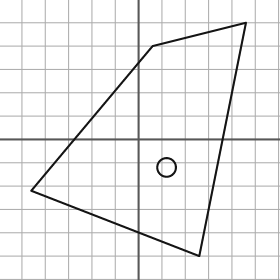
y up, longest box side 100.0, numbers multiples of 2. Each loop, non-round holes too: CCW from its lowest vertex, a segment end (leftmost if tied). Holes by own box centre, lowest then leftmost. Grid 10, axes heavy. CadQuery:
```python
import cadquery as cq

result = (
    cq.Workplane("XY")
    .moveTo(26.0, -50.0)
    .lineTo(46.0, 50.0)
    .lineTo(6.0, 40.0)
    .lineTo(-46.0, -22.0)
    .close()
    .moveTo(12.0, -12.0)
    .circle(4.0)
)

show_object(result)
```